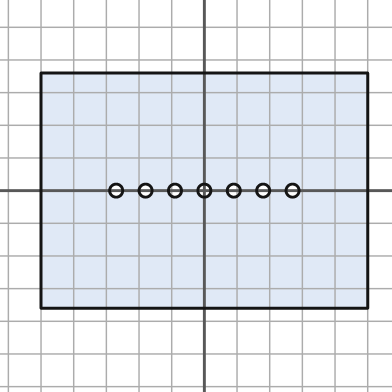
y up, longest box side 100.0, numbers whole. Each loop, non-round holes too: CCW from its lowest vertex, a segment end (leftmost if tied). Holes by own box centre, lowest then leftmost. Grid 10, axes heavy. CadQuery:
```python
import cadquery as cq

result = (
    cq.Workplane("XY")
    .moveTo(-50.0, -36.0)
    .lineTo(50.0, -36.0)
    .lineTo(50.0, 36.0)
    .lineTo(-50.0, 36.0)
    .close()
    .moveTo(-27.0, 0.0)
    .circle(2.0)
    .moveTo(-18.0, 0.0)
    .circle(2.0)
    .moveTo(-9.0, 0.0)
    .circle(2.0)
    .moveTo(0.0, 0.0)
    .circle(2.0)
    .moveTo(9.0, 0.0)
    .circle(2.0)
    .moveTo(18.0, 0.0)
    .circle(2.0)
    .moveTo(27.0, 0.0)
    .circle(2.0)
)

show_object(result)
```